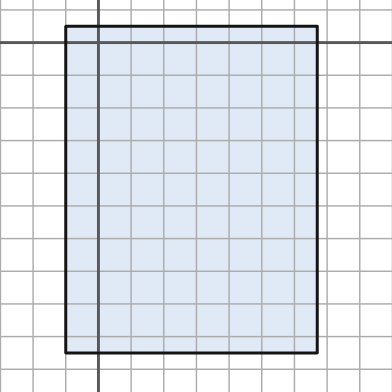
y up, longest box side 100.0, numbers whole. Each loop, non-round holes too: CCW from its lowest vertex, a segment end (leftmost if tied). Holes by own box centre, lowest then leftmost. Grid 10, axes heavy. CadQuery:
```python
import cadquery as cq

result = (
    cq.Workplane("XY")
    .moveTo(-10.0, -95.0)
    .lineTo(67.0, -95.0)
    .lineTo(67.0, 5.0)
    .lineTo(-10.0, 5.0)
    .close()
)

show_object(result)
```